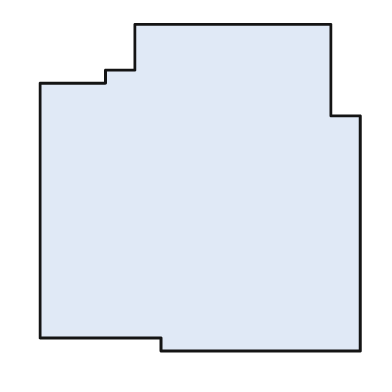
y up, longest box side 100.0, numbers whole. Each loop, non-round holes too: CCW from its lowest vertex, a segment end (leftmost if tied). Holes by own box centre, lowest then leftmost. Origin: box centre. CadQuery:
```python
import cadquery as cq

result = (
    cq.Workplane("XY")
    .moveTo(-12.0, -50.0)
    .lineTo(49.0, -50.0)
    .lineTo(49.0, 22.0)
    .lineTo(40.0, 22.0)
    .lineTo(40.0, 50.0)
    .lineTo(-20.0, 50.0)
    .lineTo(-20.0, 36.0)
    .lineTo(-29.0, 36.0)
    .lineTo(-29.0, 32.0)
    .lineTo(-49.0, 32.0)
    .lineTo(-49.0, -46.0)
    .lineTo(-12.0, -46.0)
    .close()
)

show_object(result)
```